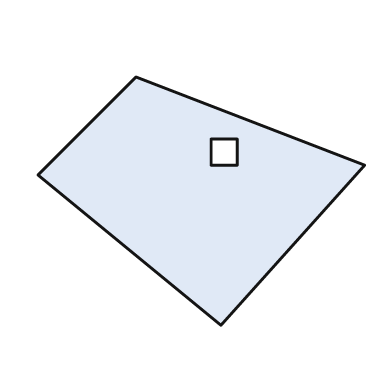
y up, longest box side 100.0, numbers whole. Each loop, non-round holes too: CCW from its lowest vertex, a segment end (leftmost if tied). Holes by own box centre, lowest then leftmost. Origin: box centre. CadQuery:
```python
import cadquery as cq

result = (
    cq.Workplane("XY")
    .moveTo(6.0, -38.0)
    .lineTo(50.0, 11.0)
    .lineTo(-20.0, 38.0)
    .lineTo(-50.0, 8.0)
    .close()
    .moveTo(3.0, 11.0)
    .lineTo(11.0, 11.0)
    .lineTo(11.0, 19.0)
    .lineTo(3.0, 19.0)
    .close()
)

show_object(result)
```